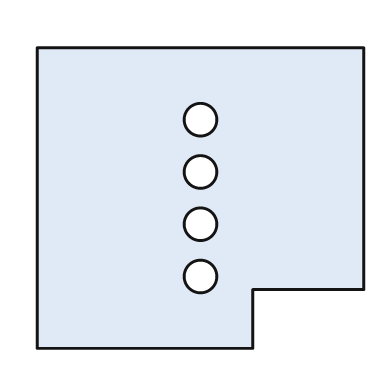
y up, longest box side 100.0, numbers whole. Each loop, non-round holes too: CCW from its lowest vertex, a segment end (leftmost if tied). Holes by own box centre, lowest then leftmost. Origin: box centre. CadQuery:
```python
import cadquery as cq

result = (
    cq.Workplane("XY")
    .moveTo(-50.0, -46.0)
    .lineTo(16.0, -46.0)
    .lineTo(16.0, -28.0)
    .lineTo(50.0, -28.0)
    .lineTo(50.0, 46.0)
    .lineTo(-50.0, 46.0)
    .close()
    .moveTo(0.0, -24.0)
    .circle(5.0)
    .moveTo(0.0, -8.0)
    .circle(5.0)
    .moveTo(0.0, 8.0)
    .circle(5.0)
    .moveTo(0.0, 24.0)
    .circle(5.0)
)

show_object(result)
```